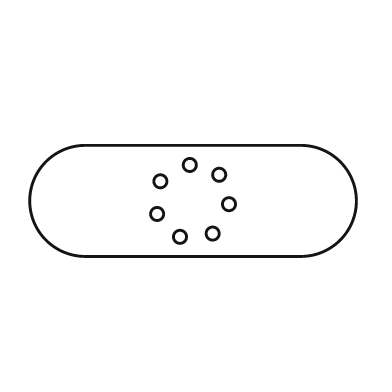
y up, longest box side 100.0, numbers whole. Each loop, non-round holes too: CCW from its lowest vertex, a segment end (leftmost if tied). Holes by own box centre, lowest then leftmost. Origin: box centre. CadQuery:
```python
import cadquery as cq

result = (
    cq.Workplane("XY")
    .moveTo(-33.0, -17.0)
    .lineTo(33.0, -17.0)
    .threePointArc((50.0, 0.0), (33.0, 17.0))
    .lineTo(-33.0, 17.0)
    .threePointArc((-50.0, 0.0), (-33.0, -17.0))
    .close()
    .moveTo(-4.0, -11.0)
    .circle(2.0)
    .moveTo(6.0, -10.0)
    .circle(2.0)
    .moveTo(-11.0, -4.0)
    .circle(2.0)
    .moveTo(11.0, -1.0)
    .circle(2.0)
    .moveTo(-10.0, 6.0)
    .circle(2.0)
    .moveTo(8.0, 8.0)
    .circle(2.0)
    .moveTo(-1.0, 11.0)
    .circle(2.0)
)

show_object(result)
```